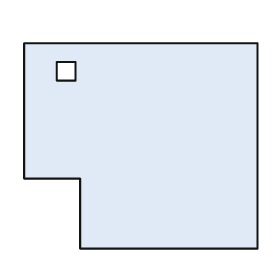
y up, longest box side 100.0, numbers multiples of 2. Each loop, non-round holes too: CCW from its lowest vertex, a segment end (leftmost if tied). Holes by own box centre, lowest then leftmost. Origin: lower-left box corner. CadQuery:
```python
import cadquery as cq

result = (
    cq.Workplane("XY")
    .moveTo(24.0, 0.0)
    .lineTo(100.0, 0.0)
    .lineTo(100.0, 88.0)
    .lineTo(0.0, 88.0)
    .lineTo(0.0, 30.0)
    .lineTo(24.0, 30.0)
    .close()
    .moveTo(14.0, 72.0)
    .lineTo(22.0, 72.0)
    .lineTo(22.0, 80.0)
    .lineTo(14.0, 80.0)
    .close()
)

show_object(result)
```